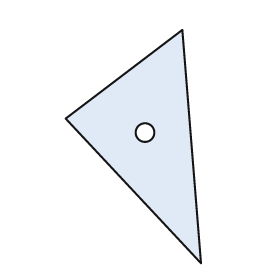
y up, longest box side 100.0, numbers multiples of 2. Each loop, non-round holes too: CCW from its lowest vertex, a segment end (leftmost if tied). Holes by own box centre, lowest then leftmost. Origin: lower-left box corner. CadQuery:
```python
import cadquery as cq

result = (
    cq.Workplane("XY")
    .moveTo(58.0, 0.0)
    .lineTo(50.0, 100.0)
    .lineTo(0.0, 62.0)
    .close()
    .moveTo(34.0, 56.0)
    .circle(4.0)
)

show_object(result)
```